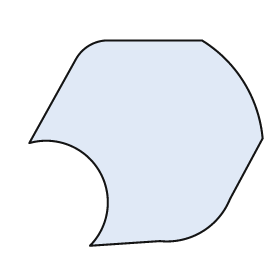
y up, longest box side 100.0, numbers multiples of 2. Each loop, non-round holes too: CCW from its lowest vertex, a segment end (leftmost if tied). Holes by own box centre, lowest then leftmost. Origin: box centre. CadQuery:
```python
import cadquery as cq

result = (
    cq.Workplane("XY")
    .moveTo(-24.0, -44.0)
    .lineTo(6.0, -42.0)
    .threePointArc((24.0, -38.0), (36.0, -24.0))
    .lineTo(50.0, 2.0)
    .threePointArc((42.0, 26.0), (24.0, 44.0))
    .lineTo(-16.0, 44.0)
    .threePointArc((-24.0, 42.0), (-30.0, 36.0))
    .lineTo(-50.0, 0.0)
    .threePointArc((-20.0, -12.0), (-24.0, -44.0))
    .close()
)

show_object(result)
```